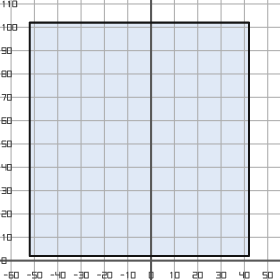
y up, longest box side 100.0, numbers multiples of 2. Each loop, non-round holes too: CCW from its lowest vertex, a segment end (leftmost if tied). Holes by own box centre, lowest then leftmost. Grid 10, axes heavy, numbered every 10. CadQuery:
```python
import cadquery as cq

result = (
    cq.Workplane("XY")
    .moveTo(-52.0, 2.0)
    .lineTo(42.0, 2.0)
    .lineTo(42.0, 102.0)
    .lineTo(-52.0, 102.0)
    .close()
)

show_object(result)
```